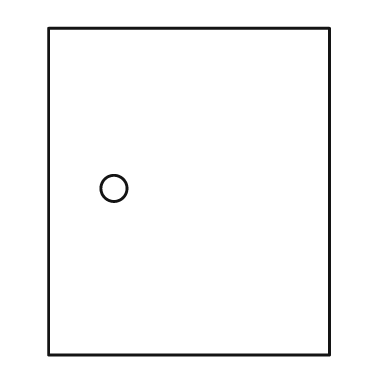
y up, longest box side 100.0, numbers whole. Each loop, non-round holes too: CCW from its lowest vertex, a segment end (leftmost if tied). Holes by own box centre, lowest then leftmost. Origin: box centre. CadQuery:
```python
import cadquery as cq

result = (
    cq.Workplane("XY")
    .moveTo(-43.0, -50.0)
    .lineTo(43.0, -50.0)
    .lineTo(43.0, 50.0)
    .lineTo(-43.0, 50.0)
    .close()
    .moveTo(-23.0, 1.0)
    .circle(4.0)
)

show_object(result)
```